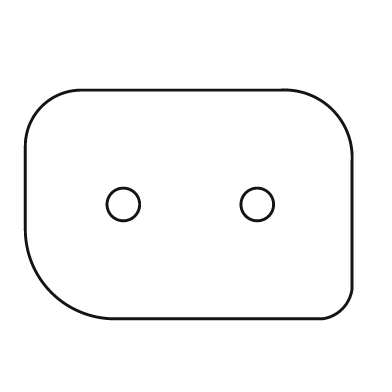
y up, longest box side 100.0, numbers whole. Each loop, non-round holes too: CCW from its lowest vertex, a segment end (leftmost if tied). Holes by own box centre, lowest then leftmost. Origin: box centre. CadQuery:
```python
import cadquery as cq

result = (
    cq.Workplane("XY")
    .moveTo(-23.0, -35.0)
    .lineTo(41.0, -35.0)
    .threePointArc((47.0, -32.0), (50.0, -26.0))
    .lineTo(50.0, 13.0)
    .threePointArc((44.0, 29.0), (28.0, 35.0))
    .lineTo(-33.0, 35.0)
    .threePointArc((-45.0, 30.0), (-50.0, 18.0))
    .lineTo(-50.0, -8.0)
    .threePointArc((-42.0, -27.0), (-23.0, -35.0))
    .close()
    .moveTo(-20.0, 0.0)
    .circle(5.0)
    .moveTo(21.0, 0.0)
    .circle(5.0)
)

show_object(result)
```